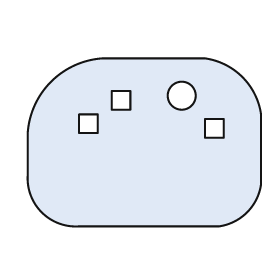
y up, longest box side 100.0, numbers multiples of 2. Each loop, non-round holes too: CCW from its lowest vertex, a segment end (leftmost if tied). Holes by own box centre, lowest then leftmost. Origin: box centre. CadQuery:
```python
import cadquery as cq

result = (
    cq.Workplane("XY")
    .moveTo(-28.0, -36.0)
    .lineTo(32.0, -36.0)
    .threePointArc((44.0, -30.0), (50.0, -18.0))
    .lineTo(50.0, 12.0)
    .threePointArc((42.0, 28.0), (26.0, 36.0))
    .lineTo(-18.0, 36.0)
    .threePointArc((-40.0, 26.0), (-50.0, 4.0))
    .lineTo(-50.0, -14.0)
    .threePointArc((-44.0, -30.0), (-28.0, -36.0))
    .close()
    .moveTo(26.0, 2.0)
    .lineTo(34.0, 2.0)
    .lineTo(34.0, 10.0)
    .lineTo(26.0, 10.0)
    .close()
    .moveTo(-28.0, 4.0)
    .lineTo(-20.0, 4.0)
    .lineTo(-20.0, 12.0)
    .lineTo(-28.0, 12.0)
    .close()
    .moveTo(-14.0, 14.0)
    .lineTo(-6.0, 14.0)
    .lineTo(-6.0, 22.0)
    .lineTo(-14.0, 22.0)
    .close()
    .moveTo(16.0, 20.0)
    .circle(6.0)
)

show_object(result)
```